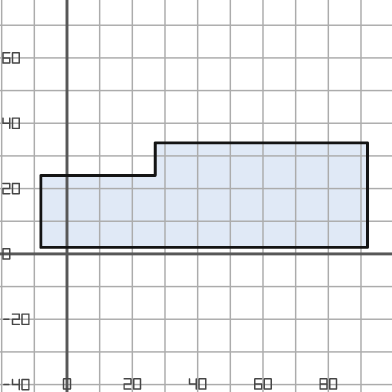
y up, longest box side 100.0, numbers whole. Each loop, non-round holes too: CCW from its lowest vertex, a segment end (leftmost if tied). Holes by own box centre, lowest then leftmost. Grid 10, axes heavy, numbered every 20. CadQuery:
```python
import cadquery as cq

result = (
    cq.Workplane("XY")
    .moveTo(-8.0, 2.0)
    .lineTo(92.0, 2.0)
    .lineTo(92.0, 34.0)
    .lineTo(27.0, 34.0)
    .lineTo(27.0, 24.0)
    .lineTo(-8.0, 24.0)
    .close()
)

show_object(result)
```